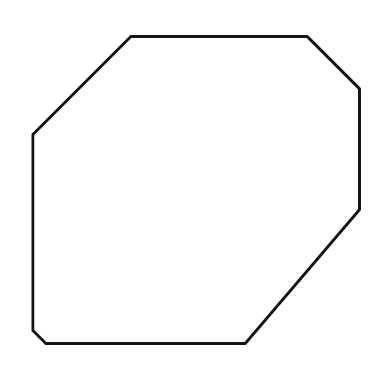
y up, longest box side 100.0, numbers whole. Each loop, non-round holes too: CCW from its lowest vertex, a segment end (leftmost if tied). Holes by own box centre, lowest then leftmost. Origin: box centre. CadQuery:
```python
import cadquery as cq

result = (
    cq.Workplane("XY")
    .moveTo(-46.0, -47.0)
    .lineTo(15.0, -47.0)
    .lineTo(50.0, -6.0)
    .lineTo(50.0, 31.0)
    .lineTo(34.0, 47.0)
    .lineTo(-20.0, 47.0)
    .lineTo(-50.0, 17.0)
    .lineTo(-50.0, -43.0)
    .close()
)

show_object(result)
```